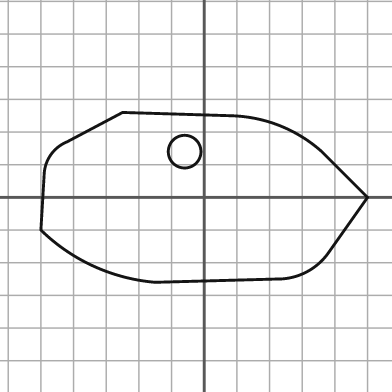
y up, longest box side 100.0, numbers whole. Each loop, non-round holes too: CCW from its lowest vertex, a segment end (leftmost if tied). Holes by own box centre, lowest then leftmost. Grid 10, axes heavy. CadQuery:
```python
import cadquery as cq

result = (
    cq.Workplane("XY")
    .moveTo(-15.0, -26.0)
    .lineTo(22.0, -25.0)
    .threePointArc((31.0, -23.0), (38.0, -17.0))
    .lineTo(50.0, 0.0)
    .lineTo(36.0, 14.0)
    .threePointArc((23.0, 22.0), (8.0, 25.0))
    .lineTo(-25.0, 26.0)
    .lineTo(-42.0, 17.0)
    .threePointArc((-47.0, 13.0), (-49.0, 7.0))
    .lineTo(-50.0, -10.0)
    .threePointArc((-34.0, -21.0), (-15.0, -26.0))
    .close()
    .moveTo(-6.0, 14.0)
    .circle(5.0)
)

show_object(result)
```